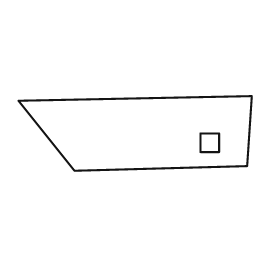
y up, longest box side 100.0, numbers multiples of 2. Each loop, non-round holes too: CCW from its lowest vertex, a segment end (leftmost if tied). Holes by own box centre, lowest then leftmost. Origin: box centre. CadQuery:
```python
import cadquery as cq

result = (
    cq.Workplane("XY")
    .moveTo(-26.0, -16.0)
    .lineTo(48.0, -14.0)
    .lineTo(50.0, 16.0)
    .lineTo(-50.0, 14.0)
    .close()
    .moveTo(28.0, -8.0)
    .lineTo(36.0, -8.0)
    .lineTo(36.0, 0.0)
    .lineTo(28.0, 0.0)
    .close()
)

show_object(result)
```